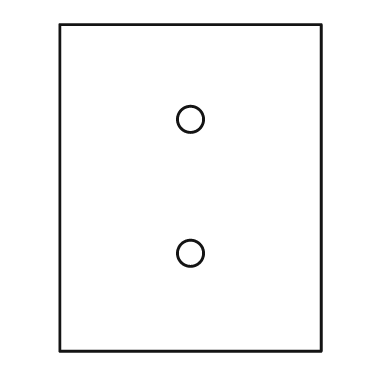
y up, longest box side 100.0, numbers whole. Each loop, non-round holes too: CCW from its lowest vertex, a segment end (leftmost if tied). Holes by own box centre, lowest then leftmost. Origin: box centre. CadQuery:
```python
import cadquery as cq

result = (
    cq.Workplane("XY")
    .moveTo(-40.0, -50.0)
    .lineTo(40.0, -50.0)
    .lineTo(40.0, 50.0)
    .lineTo(-40.0, 50.0)
    .close()
    .moveTo(0.0, -20.0)
    .circle(4.0)
    .moveTo(0.0, 21.0)
    .circle(4.0)
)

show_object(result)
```